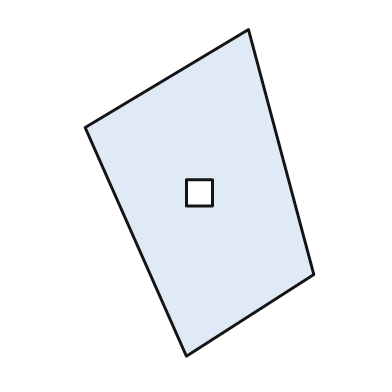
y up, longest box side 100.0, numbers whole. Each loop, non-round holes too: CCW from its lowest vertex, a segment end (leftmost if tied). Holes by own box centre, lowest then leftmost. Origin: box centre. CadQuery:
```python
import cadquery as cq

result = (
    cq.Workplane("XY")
    .moveTo(-4.0, -50.0)
    .lineTo(35.0, -25.0)
    .lineTo(15.0, 50.0)
    .lineTo(-35.0, 20.0)
    .close()
    .moveTo(-4.0, -4.0)
    .lineTo(4.0, -4.0)
    .lineTo(4.0, 4.0)
    .lineTo(-4.0, 4.0)
    .close()
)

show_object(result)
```